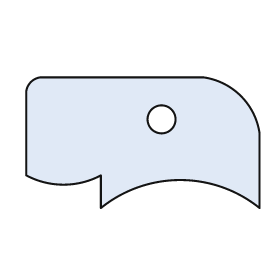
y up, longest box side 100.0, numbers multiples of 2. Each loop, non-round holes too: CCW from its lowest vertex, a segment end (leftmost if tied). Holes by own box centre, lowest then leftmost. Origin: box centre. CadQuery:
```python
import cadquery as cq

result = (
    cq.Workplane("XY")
    .moveTo(-18.0, -28.0)
    .threePointArc((16.0, -16.0), (50.0, -28.0))
    .lineTo(50.0, 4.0)
    .threePointArc((42.0, 20.0), (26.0, 28.0))
    .lineTo(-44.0, 28.0)
    .threePointArc((-48.0, 26.0), (-50.0, 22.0))
    .lineTo(-50.0, -14.0)
    .threePointArc((-34.0, -18.0), (-18.0, -14.0))
    .close()
    .moveTo(8.0, 10.0)
    .circle(6.0)
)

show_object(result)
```